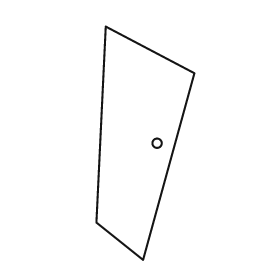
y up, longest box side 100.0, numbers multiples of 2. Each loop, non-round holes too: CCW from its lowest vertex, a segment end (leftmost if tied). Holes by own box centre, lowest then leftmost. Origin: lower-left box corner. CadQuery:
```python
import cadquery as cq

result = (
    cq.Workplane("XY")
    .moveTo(20.0, 0.0)
    .lineTo(42.0, 80.0)
    .lineTo(4.0, 100.0)
    .lineTo(0.0, 16.0)
    .close()
    .moveTo(26.0, 50.0)
    .circle(2.0)
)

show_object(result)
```